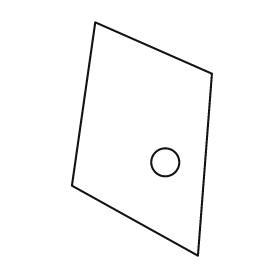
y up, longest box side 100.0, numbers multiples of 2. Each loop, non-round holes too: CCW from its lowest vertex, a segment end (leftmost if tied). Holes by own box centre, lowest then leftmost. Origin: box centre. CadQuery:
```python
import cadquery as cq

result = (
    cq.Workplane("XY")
    .moveTo(24.0, -50.0)
    .lineTo(30.0, 28.0)
    .lineTo(-20.0, 50.0)
    .lineTo(-30.0, -20.0)
    .close()
    .moveTo(10.0, -10.0)
    .circle(6.0)
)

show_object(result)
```